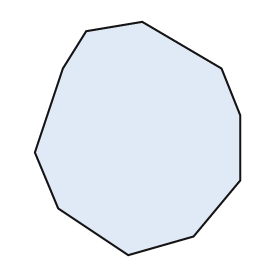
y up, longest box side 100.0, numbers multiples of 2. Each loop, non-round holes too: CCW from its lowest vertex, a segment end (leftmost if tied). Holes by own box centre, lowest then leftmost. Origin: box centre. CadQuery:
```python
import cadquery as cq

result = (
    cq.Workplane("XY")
    .moveTo(-4.0, -50.0)
    .lineTo(24.0, -42.0)
    .lineTo(44.0, -18.0)
    .lineTo(44.0, 10.0)
    .lineTo(36.0, 30.0)
    .lineTo(2.0, 50.0)
    .lineTo(-22.0, 46.0)
    .lineTo(-32.0, 30.0)
    .lineTo(-44.0, -6.0)
    .lineTo(-34.0, -30.0)
    .close()
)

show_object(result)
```